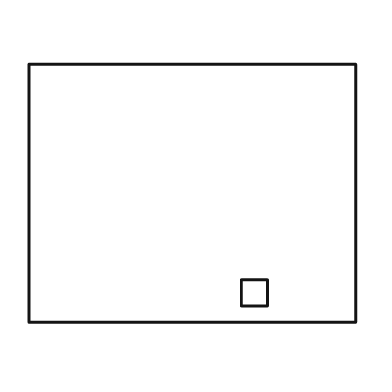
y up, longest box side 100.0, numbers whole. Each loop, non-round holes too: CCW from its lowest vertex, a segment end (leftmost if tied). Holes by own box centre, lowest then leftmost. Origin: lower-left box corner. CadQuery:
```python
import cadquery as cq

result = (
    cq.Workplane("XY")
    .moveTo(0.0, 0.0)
    .lineTo(100.0, 0.0)
    .lineTo(100.0, 79.0)
    .lineTo(0.0, 79.0)
    .close()
    .moveTo(65.0, 5.0)
    .lineTo(73.0, 5.0)
    .lineTo(73.0, 13.0)
    .lineTo(65.0, 13.0)
    .close()
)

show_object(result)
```